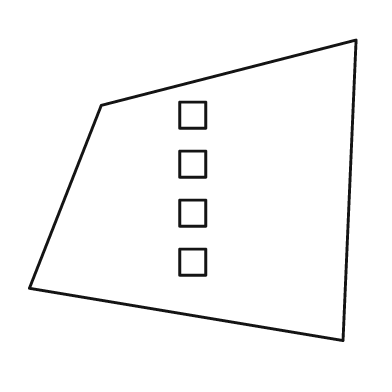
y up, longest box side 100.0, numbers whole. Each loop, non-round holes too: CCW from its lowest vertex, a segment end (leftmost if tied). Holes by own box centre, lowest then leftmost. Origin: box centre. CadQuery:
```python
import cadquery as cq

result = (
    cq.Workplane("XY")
    .moveTo(46.0, -46.0)
    .lineTo(50.0, 46.0)
    .lineTo(-28.0, 26.0)
    .lineTo(-50.0, -30.0)
    .close()
    .moveTo(-4.0, -26.0)
    .lineTo(4.0, -26.0)
    .lineTo(4.0, -18.0)
    .lineTo(-4.0, -18.0)
    .close()
    .moveTo(-4.0, -11.0)
    .lineTo(4.0, -11.0)
    .lineTo(4.0, -3.0)
    .lineTo(-4.0, -3.0)
    .close()
    .moveTo(-4.0, 4.0)
    .lineTo(4.0, 4.0)
    .lineTo(4.0, 12.0)
    .lineTo(-4.0, 12.0)
    .close()
    .moveTo(-4.0, 19.0)
    .lineTo(4.0, 19.0)
    .lineTo(4.0, 27.0)
    .lineTo(-4.0, 27.0)
    .close()
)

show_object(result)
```